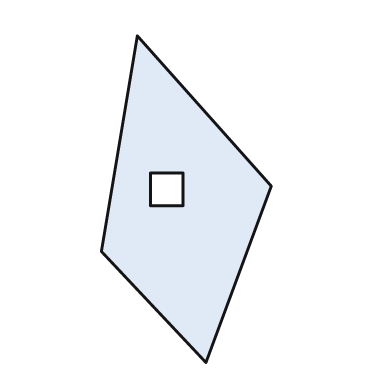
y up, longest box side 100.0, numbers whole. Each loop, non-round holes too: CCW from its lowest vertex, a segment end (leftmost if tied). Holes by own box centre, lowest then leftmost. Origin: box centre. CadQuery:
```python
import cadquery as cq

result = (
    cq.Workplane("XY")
    .moveTo(6.0, -50.0)
    .lineTo(26.0, 4.0)
    .lineTo(-15.0, 50.0)
    .lineTo(-26.0, -16.0)
    .close()
    .moveTo(-11.0, -2.0)
    .lineTo(-1.0, -2.0)
    .lineTo(-1.0, 8.0)
    .lineTo(-11.0, 8.0)
    .close()
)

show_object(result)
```